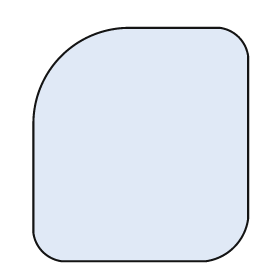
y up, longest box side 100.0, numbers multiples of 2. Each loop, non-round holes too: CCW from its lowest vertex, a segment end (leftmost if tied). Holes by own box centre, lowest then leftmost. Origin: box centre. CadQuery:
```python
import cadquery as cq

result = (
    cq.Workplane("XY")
    .moveTo(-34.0, -50.0)
    .lineTo(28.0, -50.0)
    .threePointArc((40.0, -44.0), (46.0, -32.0))
    .lineTo(46.0, 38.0)
    .threePointArc((42.0, 46.0), (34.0, 50.0))
    .lineTo(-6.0, 50.0)
    .threePointArc((-34.0, 38.0), (-46.0, 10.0))
    .lineTo(-46.0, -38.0)
    .threePointArc((-42.0, -46.0), (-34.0, -50.0))
    .close()
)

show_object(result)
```